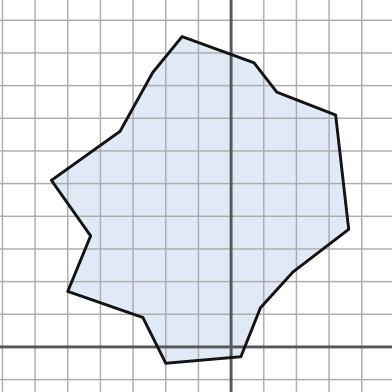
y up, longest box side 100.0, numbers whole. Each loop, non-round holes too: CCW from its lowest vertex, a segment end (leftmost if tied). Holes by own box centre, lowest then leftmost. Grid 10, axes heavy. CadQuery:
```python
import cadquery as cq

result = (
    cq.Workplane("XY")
    .moveTo(-20.0, -5.0)
    .lineTo(3.0, -3.0)
    .lineTo(9.0, 12.0)
    .lineTo(19.0, 23.0)
    .lineTo(36.0, 36.0)
    .lineTo(32.0, 71.0)
    .lineTo(14.0, 78.0)
    .lineTo(7.0, 87.0)
    .lineTo(-15.0, 95.0)
    .lineTo(-24.0, 84.0)
    .lineTo(-34.0, 66.0)
    .lineTo(-55.0, 51.0)
    .lineTo(-43.0, 34.0)
    .lineTo(-50.0, 17.0)
    .lineTo(-27.0, 9.0)
    .close()
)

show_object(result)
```